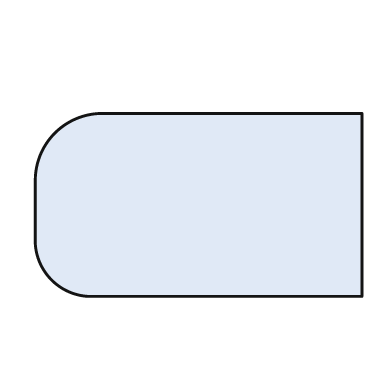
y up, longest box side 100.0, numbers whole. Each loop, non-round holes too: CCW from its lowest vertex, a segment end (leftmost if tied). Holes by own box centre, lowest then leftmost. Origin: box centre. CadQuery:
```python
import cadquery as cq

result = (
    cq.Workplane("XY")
    .moveTo(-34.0, -28.0)
    .lineTo(50.0, -28.0)
    .lineTo(50.0, 28.0)
    .lineTo(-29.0, 28.0)
    .threePointArc((-44.0, 22.0), (-50.0, 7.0))
    .lineTo(-50.0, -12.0)
    .threePointArc((-45.0, -23.0), (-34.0, -28.0))
    .close()
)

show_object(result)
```